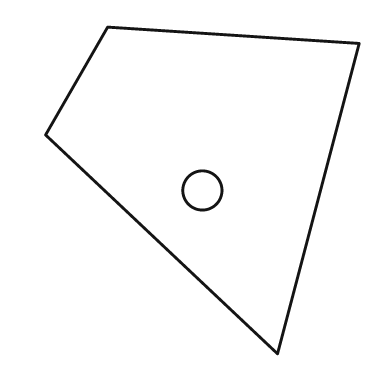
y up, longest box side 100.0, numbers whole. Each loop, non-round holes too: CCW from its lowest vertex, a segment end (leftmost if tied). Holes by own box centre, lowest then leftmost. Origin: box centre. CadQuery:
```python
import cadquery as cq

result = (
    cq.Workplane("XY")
    .moveTo(23.0, -50.0)
    .lineTo(48.0, 45.0)
    .lineTo(-29.0, 50.0)
    .lineTo(-48.0, 17.0)
    .close()
    .moveTo(0.0, 0.0)
    .circle(6.0)
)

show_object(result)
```